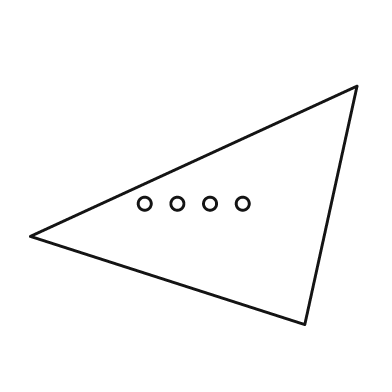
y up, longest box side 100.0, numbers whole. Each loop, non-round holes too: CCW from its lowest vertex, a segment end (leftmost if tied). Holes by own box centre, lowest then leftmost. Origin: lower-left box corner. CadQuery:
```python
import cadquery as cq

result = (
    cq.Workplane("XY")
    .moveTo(84.0, 0.0)
    .lineTo(100.0, 73.0)
    .lineTo(0.0, 27.0)
    .close()
    .moveTo(35.0, 37.0)
    .circle(2.0)
    .moveTo(45.0, 37.0)
    .circle(2.0)
    .moveTo(55.0, 37.0)
    .circle(2.0)
    .moveTo(65.0, 37.0)
    .circle(2.0)
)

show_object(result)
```